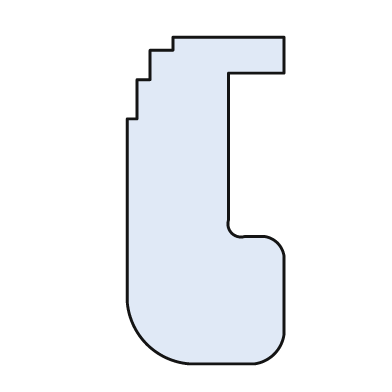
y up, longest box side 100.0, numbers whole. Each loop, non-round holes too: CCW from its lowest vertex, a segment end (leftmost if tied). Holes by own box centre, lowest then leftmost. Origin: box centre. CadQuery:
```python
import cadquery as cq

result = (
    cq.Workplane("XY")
    .moveTo(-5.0, -50.0)
    .lineTo(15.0, -50.0)
    .threePointArc((21.0, -47.0), (24.0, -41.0))
    .lineTo(24.0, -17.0)
    .threePointArc((22.0, -13.0), (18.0, -11.0))
    .lineTo(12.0, -11.0)
    .threePointArc((8.0, -10.0), (7.0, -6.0))
    .lineTo(7.0, 39.0)
    .lineTo(24.0, 39.0)
    .lineTo(24.0, 50.0)
    .lineTo(-10.0, 50.0)
    .lineTo(-10.0, 46.0)
    .lineTo(-17.0, 46.0)
    .lineTo(-17.0, 37.0)
    .lineTo(-21.0, 37.0)
    .lineTo(-21.0, 25.0)
    .lineTo(-24.0, 25.0)
    .lineTo(-24.0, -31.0)
    .threePointArc((-18.0, -44.0), (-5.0, -50.0))
    .close()
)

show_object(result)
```